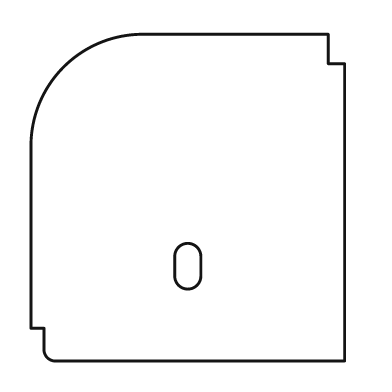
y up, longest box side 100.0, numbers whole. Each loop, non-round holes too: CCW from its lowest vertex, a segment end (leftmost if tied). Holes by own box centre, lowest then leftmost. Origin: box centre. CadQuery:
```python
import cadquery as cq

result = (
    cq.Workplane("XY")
    .moveTo(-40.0, -50.0)
    .lineTo(48.0, -50.0)
    .lineTo(48.0, 41.0)
    .lineTo(43.0, 41.0)
    .lineTo(43.0, 50.0)
    .lineTo(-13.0, 50.0)
    .threePointArc((-38.0, 40.0), (-48.0, 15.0))
    .lineTo(-48.0, -40.0)
    .lineTo(-44.0, -40.0)
    .lineTo(-44.0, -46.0)
    .threePointArc((-43.0, -49.0), (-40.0, -50.0))
    .close()
    .moveTo(-4.0, -24.0)
    .threePointArc((0.0, -28.0), (4.0, -24.0))
    .lineTo(4.0, -18.0)
    .threePointArc((0.0, -14.0), (-4.0, -18.0))
    .close()
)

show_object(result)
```